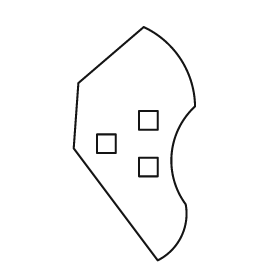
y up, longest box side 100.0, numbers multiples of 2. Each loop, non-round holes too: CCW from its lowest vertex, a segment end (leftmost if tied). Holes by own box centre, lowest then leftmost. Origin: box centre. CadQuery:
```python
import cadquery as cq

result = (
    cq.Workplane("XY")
    .moveTo(10.0, -50.0)
    .threePointArc((20.0, -40.0), (22.0, -26.0))
    .threePointArc((16.0, -4.0), (26.0, 16.0))
    .threePointArc((20.0, 36.0), (4.0, 50.0))
    .lineTo(-24.0, 26.0)
    .lineTo(-26.0, -2.0)
    .close()
    .moveTo(2.0, -14.0)
    .lineTo(10.0, -14.0)
    .lineTo(10.0, -6.0)
    .lineTo(2.0, -6.0)
    .close()
    .moveTo(-16.0, -4.0)
    .lineTo(-8.0, -4.0)
    .lineTo(-8.0, 4.0)
    .lineTo(-16.0, 4.0)
    .close()
    .moveTo(2.0, 6.0)
    .lineTo(10.0, 6.0)
    .lineTo(10.0, 14.0)
    .lineTo(2.0, 14.0)
    .close()
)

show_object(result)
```